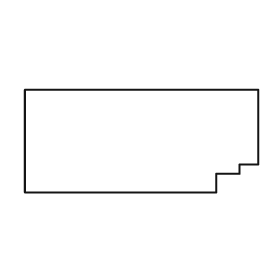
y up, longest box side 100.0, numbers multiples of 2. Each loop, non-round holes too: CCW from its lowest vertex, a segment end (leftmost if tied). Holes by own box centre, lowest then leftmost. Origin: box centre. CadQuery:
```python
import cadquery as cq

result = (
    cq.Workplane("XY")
    .moveTo(-50.0, -22.0)
    .lineTo(32.0, -22.0)
    .lineTo(32.0, -14.0)
    .lineTo(42.0, -14.0)
    .lineTo(42.0, -10.0)
    .lineTo(50.0, -10.0)
    .lineTo(50.0, 22.0)
    .lineTo(-50.0, 22.0)
    .close()
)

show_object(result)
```